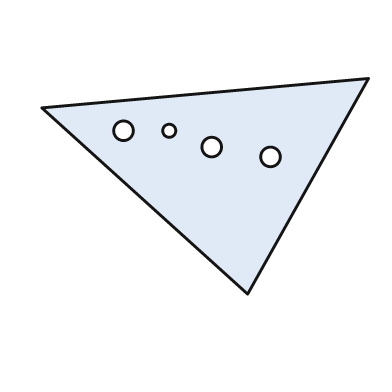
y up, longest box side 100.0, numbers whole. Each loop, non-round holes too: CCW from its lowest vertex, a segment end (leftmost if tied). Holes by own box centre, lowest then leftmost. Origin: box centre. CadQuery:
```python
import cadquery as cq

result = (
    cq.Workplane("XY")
    .moveTo(13.0, -33.0)
    .lineTo(50.0, 33.0)
    .lineTo(-50.0, 24.0)
    .close()
    .moveTo(20.0, 9.0)
    .circle(3.0)
    .moveTo(2.0, 12.0)
    .circle(3.0)
    .moveTo(-25.0, 17.0)
    .circle(3.0)
    .moveTo(-11.0, 17.0)
    .circle(2.0)
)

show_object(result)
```